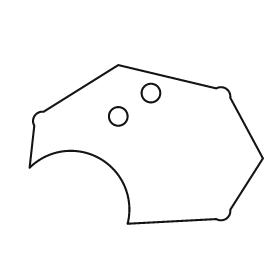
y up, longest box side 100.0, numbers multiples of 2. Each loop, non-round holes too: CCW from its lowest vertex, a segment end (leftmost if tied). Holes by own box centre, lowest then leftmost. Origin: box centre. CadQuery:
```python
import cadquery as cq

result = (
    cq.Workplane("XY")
    .moveTo(-8.0, -34.0)
    .lineTo(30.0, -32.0)
    .threePointArc((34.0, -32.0), (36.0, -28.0))
    .lineTo(50.0, -6.0)
    .lineTo(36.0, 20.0)
    .threePointArc((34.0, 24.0), (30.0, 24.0))
    .lineTo(-12.0, 34.0)
    .lineTo(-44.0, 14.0)
    .threePointArc((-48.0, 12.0), (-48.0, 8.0))
    .lineTo(-50.0, -10.0)
    .threePointArc((-20.0, -6.0), (-8.0, -34.0))
    .close()
    .moveTo(-12.0, 12.0)
    .circle(4.0)
    .moveTo(2.0, 22.0)
    .circle(4.0)
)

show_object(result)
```